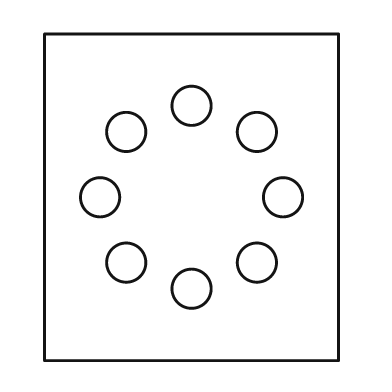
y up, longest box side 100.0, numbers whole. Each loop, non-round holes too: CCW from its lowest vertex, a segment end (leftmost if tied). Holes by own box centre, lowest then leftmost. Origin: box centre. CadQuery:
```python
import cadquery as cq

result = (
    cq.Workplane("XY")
    .moveTo(-45.0, -50.0)
    .lineTo(45.0, -50.0)
    .lineTo(45.0, 50.0)
    .lineTo(-45.0, 50.0)
    .close()
    .moveTo(0.0, -28.0)
    .circle(6.0)
    .moveTo(-20.0, -20.0)
    .circle(6.0)
    .moveTo(20.0, -20.0)
    .circle(6.0)
    .moveTo(-28.0, 0.0)
    .circle(6.0)
    .moveTo(28.0, 0.0)
    .circle(6.0)
    .moveTo(-20.0, 20.0)
    .circle(6.0)
    .moveTo(20.0, 20.0)
    .circle(6.0)
    .moveTo(0.0, 28.0)
    .circle(6.0)
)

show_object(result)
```